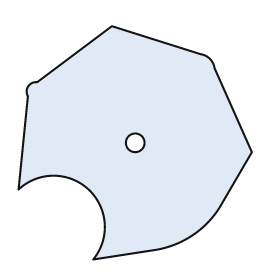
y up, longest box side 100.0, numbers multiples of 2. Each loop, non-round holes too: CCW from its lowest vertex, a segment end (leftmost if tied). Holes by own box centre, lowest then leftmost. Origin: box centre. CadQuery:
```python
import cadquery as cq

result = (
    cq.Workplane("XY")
    .moveTo(-18.0, -50.0)
    .lineTo(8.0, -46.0)
    .threePointArc((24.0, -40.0), (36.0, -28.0))
    .lineTo(50.0, -4.0)
    .lineTo(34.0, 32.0)
    .threePointArc((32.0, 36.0), (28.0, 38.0))
    .lineTo(-10.0, 50.0)
    .lineTo(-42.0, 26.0)
    .threePointArc((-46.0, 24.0), (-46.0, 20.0))
    .lineTo(-50.0, -20.0)
    .threePointArc((-20.0, -20.0), (-18.0, -50.0))
    .close()
    .moveTo(0.0, 0.0)
    .circle(4.0)
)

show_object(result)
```